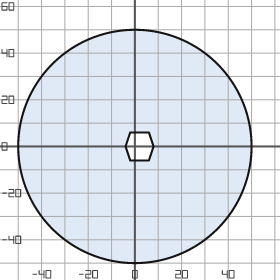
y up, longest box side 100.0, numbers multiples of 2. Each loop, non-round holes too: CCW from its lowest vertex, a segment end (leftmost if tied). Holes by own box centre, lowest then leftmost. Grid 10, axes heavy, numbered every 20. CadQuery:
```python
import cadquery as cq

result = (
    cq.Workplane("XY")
    .moveTo(0.0, 0.0)
    .circle(50.0)
    .moveTo(-2.0, -6.0)
    .lineTo(6.0, -6.0)
    .lineTo(8.0, 0.0)
    .lineTo(6.0, 6.0)
    .lineTo(-2.0, 6.0)
    .lineTo(-4.0, 0.0)
    .close()
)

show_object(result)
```